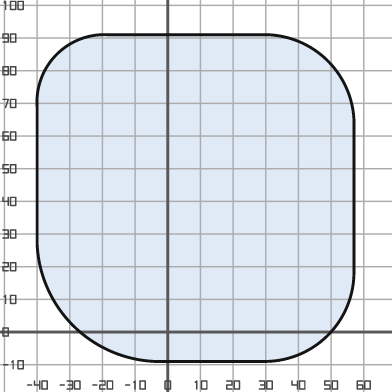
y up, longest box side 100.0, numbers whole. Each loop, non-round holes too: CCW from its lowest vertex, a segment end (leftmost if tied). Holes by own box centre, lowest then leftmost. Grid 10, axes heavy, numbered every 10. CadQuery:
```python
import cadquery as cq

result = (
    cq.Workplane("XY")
    .moveTo(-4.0, -9.0)
    .lineTo(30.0, -9.0)
    .threePointArc((49.0, -1.0), (57.0, 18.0))
    .lineTo(57.0, 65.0)
    .threePointArc((49.0, 83.0), (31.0, 91.0))
    .lineTo(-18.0, 91.0)
    .threePointArc((-34.0, 85.0), (-40.0, 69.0))
    .lineTo(-40.0, 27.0)
    .threePointArc((-29.0, 2.0), (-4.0, -9.0))
    .close()
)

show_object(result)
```